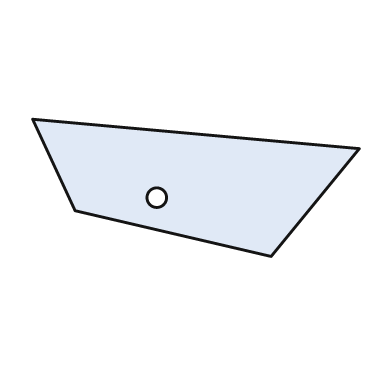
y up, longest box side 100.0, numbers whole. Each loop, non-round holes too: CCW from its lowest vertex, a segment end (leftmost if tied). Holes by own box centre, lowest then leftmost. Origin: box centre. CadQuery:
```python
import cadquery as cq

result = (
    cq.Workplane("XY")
    .moveTo(23.0, -21.0)
    .lineTo(50.0, 12.0)
    .lineTo(-50.0, 21.0)
    .lineTo(-37.0, -7.0)
    .close()
    .moveTo(-12.0, -3.0)
    .circle(3.0)
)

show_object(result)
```